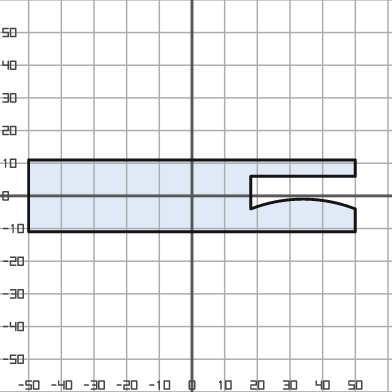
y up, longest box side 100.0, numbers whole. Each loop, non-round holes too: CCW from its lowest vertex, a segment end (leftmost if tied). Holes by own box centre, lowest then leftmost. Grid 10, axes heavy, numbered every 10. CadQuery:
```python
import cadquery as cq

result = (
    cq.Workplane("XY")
    .moveTo(-50.0, -11.0)
    .lineTo(50.0, -11.0)
    .lineTo(50.0, -4.0)
    .threePointArc((34.0, -1.0), (18.0, -4.0))
    .lineTo(18.0, 6.0)
    .lineTo(50.0, 6.0)
    .lineTo(50.0, 11.0)
    .lineTo(-50.0, 11.0)
    .close()
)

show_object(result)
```